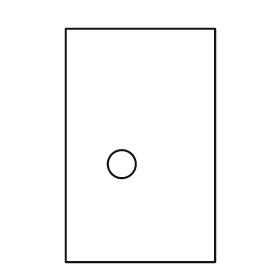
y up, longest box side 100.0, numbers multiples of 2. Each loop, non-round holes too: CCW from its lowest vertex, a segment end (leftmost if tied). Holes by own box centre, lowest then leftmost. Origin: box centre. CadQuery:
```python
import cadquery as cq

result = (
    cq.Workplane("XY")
    .moveTo(-32.0, -50.0)
    .lineTo(32.0, -50.0)
    .lineTo(32.0, 50.0)
    .lineTo(-32.0, 50.0)
    .close()
    .moveTo(-8.0, -8.0)
    .circle(6.0)
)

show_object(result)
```